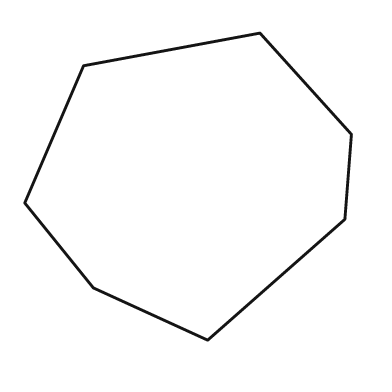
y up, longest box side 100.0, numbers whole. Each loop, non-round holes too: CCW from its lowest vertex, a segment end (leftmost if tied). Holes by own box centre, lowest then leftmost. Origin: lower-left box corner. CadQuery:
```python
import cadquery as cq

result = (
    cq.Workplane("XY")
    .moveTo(56.0, 0.0)
    .lineTo(98.0, 37.0)
    .lineTo(100.0, 63.0)
    .lineTo(72.0, 94.0)
    .lineTo(18.0, 84.0)
    .lineTo(0.0, 42.0)
    .lineTo(21.0, 16.0)
    .close()
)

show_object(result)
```